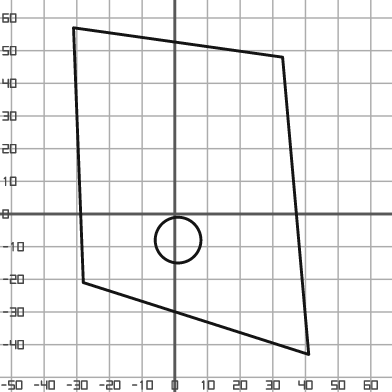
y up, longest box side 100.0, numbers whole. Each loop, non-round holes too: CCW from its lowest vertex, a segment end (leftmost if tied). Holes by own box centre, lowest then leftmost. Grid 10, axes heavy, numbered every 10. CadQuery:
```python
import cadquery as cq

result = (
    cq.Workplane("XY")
    .moveTo(41.0, -43.0)
    .lineTo(33.0, 48.0)
    .lineTo(-31.0, 57.0)
    .lineTo(-28.0, -21.0)
    .close()
    .moveTo(1.0, -8.0)
    .circle(7.0)
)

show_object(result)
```